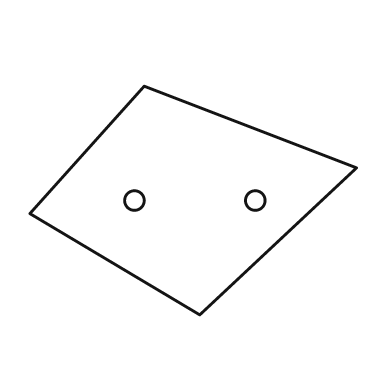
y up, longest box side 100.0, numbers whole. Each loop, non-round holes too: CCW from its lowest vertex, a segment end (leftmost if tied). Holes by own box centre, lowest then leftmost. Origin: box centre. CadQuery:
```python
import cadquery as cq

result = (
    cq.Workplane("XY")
    .moveTo(2.0, -35.0)
    .lineTo(50.0, 10.0)
    .lineTo(-15.0, 35.0)
    .lineTo(-50.0, -4.0)
    .close()
    .moveTo(-18.0, 0.0)
    .circle(3.0)
    .moveTo(19.0, 0.0)
    .circle(3.0)
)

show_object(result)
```